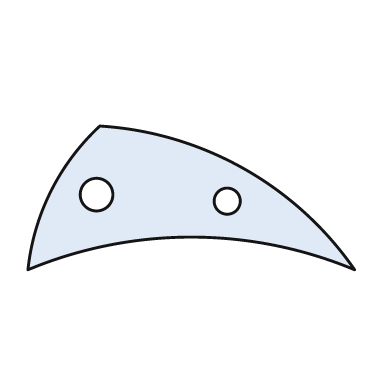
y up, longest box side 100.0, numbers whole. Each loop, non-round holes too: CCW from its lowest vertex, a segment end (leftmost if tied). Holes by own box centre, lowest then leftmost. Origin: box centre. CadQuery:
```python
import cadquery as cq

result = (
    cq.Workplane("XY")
    .moveTo(-50.0, -22.0)
    .threePointArc((0.0, -12.0), (50.0, -22.0))
    .threePointArc((16.0, 9.0), (-28.0, 22.0))
    .threePointArc((-43.0, 2.0), (-50.0, -22.0))
    .close()
    .moveTo(11.0, -1.0)
    .circle(4.0)
    .moveTo(-29.0, 1.0)
    .circle(5.0)
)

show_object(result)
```